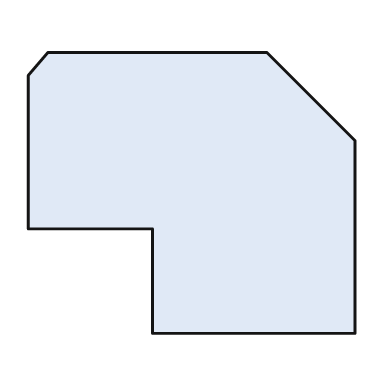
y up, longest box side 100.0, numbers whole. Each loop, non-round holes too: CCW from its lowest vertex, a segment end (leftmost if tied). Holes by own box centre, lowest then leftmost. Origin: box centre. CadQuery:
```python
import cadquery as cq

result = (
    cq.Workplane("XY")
    .moveTo(-12.0, -43.0)
    .lineTo(50.0, -43.0)
    .lineTo(50.0, 16.0)
    .lineTo(23.0, 43.0)
    .lineTo(-44.0, 43.0)
    .lineTo(-50.0, 36.0)
    .lineTo(-50.0, -11.0)
    .lineTo(-12.0, -11.0)
    .close()
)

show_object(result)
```